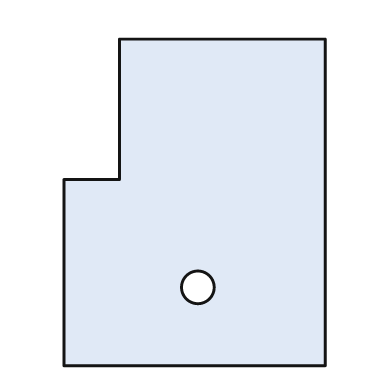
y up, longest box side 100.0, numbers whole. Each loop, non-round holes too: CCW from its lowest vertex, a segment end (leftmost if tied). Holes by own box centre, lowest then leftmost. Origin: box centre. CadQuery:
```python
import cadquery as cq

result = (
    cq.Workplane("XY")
    .moveTo(-40.0, -50.0)
    .lineTo(40.0, -50.0)
    .lineTo(40.0, 50.0)
    .lineTo(-23.0, 50.0)
    .lineTo(-23.0, 7.0)
    .lineTo(-40.0, 7.0)
    .close()
    .moveTo(1.0, -26.0)
    .circle(5.0)
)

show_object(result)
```